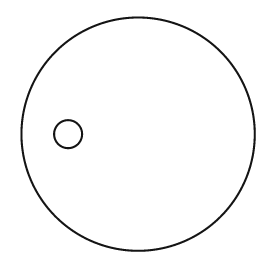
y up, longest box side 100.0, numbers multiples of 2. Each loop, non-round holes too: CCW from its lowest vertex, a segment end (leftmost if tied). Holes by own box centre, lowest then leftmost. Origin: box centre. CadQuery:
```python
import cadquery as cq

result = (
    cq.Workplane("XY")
    .moveTo(0.0, 0.0)
    .circle(50.0)
    .moveTo(-30.0, 0.0)
    .circle(6.0)
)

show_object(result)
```